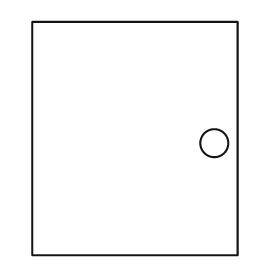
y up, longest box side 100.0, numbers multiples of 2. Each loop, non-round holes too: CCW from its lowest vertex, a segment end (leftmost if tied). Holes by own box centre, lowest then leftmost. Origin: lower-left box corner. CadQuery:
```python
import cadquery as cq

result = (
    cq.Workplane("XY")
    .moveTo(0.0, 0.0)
    .lineTo(88.0, 0.0)
    .lineTo(88.0, 100.0)
    .lineTo(0.0, 100.0)
    .close()
    .moveTo(78.0, 48.0)
    .circle(6.0)
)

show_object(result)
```